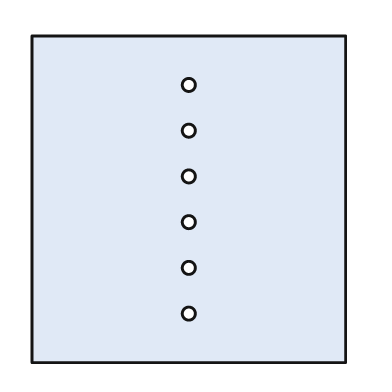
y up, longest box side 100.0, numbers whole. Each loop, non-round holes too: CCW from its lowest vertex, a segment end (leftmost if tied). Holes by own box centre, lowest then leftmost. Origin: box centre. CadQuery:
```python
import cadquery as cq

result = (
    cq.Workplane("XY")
    .moveTo(-48.0, -50.0)
    .lineTo(48.0, -50.0)
    .lineTo(48.0, 50.0)
    .lineTo(-48.0, 50.0)
    .close()
    .moveTo(0.0, -35.0)
    .circle(2.0)
    .moveTo(0.0, -21.0)
    .circle(2.0)
    .moveTo(0.0, -7.0)
    .circle(2.0)
    .moveTo(0.0, 7.0)
    .circle(2.0)
    .moveTo(0.0, 21.0)
    .circle(2.0)
    .moveTo(0.0, 35.0)
    .circle(2.0)
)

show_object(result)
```